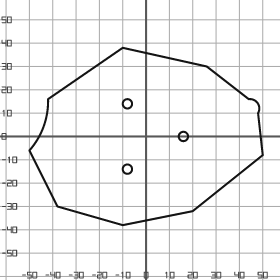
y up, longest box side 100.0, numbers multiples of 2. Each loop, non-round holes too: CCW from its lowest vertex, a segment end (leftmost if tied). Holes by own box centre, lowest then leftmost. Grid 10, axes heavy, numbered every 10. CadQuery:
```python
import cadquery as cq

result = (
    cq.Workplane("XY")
    .moveTo(-10.0, -38.0)
    .lineTo(20.0, -32.0)
    .lineTo(50.0, -8.0)
    .lineTo(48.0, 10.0)
    .threePointArc((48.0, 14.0), (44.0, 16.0))
    .lineTo(26.0, 30.0)
    .lineTo(-10.0, 38.0)
    .lineTo(-42.0, 16.0)
    .threePointArc((-44.0, 4.0), (-50.0, -6.0))
    .lineTo(-38.0, -30.0)
    .close()
    .moveTo(-8.0, -14.0)
    .circle(2.0)
    .moveTo(16.0, 0.0)
    .circle(2.0)
    .moveTo(-8.0, 14.0)
    .circle(2.0)
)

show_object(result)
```